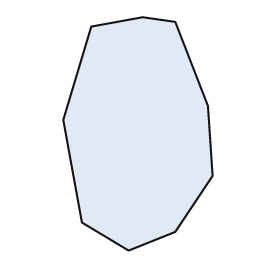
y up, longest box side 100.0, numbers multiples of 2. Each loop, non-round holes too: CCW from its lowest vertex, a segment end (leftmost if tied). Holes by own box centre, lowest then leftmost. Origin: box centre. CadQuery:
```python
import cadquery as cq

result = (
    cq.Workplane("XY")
    .moveTo(-4.0, -50.0)
    .lineTo(16.0, -42.0)
    .lineTo(32.0, -18.0)
    .lineTo(30.0, 12.0)
    .lineTo(16.0, 48.0)
    .lineTo(2.0, 50.0)
    .lineTo(-20.0, 46.0)
    .lineTo(-32.0, 6.0)
    .lineTo(-24.0, -38.0)
    .close()
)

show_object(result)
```